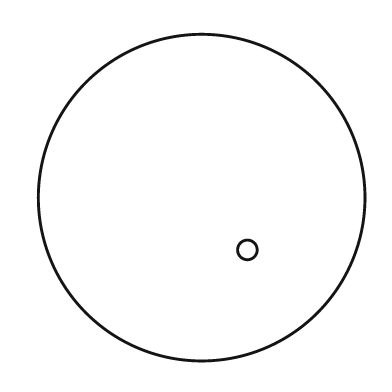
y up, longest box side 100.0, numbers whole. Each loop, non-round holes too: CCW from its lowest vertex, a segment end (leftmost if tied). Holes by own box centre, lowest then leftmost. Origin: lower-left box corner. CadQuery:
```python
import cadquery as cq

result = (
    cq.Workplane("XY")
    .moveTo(50.0, 50.0)
    .circle(50.0)
    .moveTo(64.0, 34.0)
    .circle(3.0)
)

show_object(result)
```